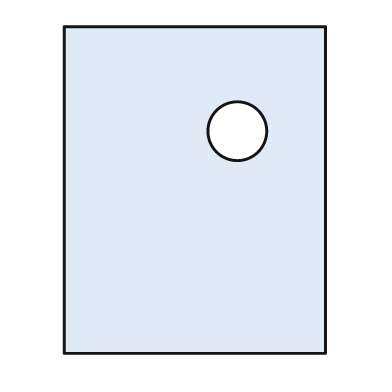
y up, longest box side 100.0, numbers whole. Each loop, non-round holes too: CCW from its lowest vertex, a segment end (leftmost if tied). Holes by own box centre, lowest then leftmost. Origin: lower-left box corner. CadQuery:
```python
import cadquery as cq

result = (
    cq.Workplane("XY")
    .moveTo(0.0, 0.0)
    .lineTo(80.0, 0.0)
    .lineTo(80.0, 100.0)
    .lineTo(0.0, 100.0)
    .close()
    .moveTo(53.0, 68.0)
    .circle(9.0)
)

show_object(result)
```